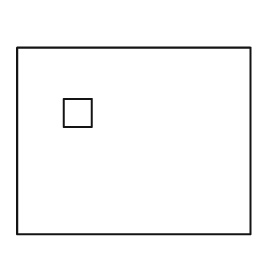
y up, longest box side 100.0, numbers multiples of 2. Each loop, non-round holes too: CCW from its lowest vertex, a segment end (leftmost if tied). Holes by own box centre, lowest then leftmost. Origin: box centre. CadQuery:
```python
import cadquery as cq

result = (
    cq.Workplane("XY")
    .moveTo(-50.0, -40.0)
    .lineTo(50.0, -40.0)
    .lineTo(50.0, 40.0)
    .lineTo(-50.0, 40.0)
    .close()
    .moveTo(-30.0, 6.0)
    .lineTo(-18.0, 6.0)
    .lineTo(-18.0, 18.0)
    .lineTo(-30.0, 18.0)
    .close()
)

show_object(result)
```